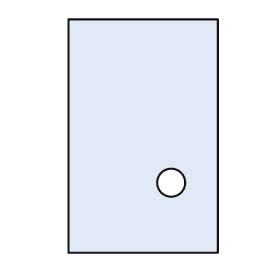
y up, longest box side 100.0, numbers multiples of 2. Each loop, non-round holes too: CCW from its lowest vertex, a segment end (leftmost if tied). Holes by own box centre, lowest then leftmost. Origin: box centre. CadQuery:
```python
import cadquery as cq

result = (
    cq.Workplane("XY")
    .moveTo(-32.0, -50.0)
    .lineTo(32.0, -50.0)
    .lineTo(32.0, 50.0)
    .lineTo(-32.0, 50.0)
    .close()
    .moveTo(12.0, -20.0)
    .circle(6.0)
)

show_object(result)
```